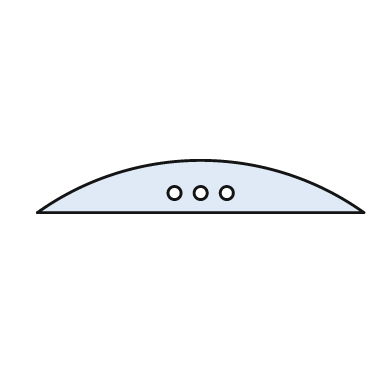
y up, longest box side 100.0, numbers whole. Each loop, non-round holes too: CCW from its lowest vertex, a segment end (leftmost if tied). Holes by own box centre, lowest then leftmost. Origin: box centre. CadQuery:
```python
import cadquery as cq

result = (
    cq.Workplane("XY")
    .moveTo(-50.0, -8.0)
    .lineTo(50.0, -8.0)
    .threePointArc((0.0, 8.0), (-50.0, -8.0))
    .close()
    .moveTo(-8.0, -2.0)
    .circle(2.0)
    .moveTo(0.0, -2.0)
    .circle(2.0)
    .moveTo(8.0, -2.0)
    .circle(2.0)
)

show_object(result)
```